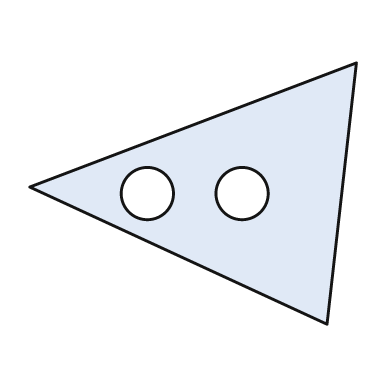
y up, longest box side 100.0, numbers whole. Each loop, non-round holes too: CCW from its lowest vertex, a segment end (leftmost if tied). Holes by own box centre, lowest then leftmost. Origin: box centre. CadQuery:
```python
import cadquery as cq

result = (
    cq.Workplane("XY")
    .moveTo(41.0, -40.0)
    .lineTo(50.0, 40.0)
    .lineTo(-50.0, 2.0)
    .close()
    .moveTo(-14.0, 0.0)
    .circle(8.0)
    .moveTo(15.0, 0.0)
    .circle(8.0)
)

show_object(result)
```